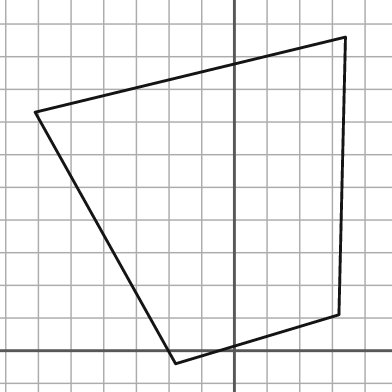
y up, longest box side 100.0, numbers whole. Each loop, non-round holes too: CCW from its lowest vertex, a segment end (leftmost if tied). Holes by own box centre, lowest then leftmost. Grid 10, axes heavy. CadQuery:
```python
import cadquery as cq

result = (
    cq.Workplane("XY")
    .moveTo(-18.0, -4.0)
    .lineTo(32.0, 11.0)
    .lineTo(34.0, 96.0)
    .lineTo(-61.0, 73.0)
    .close()
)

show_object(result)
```